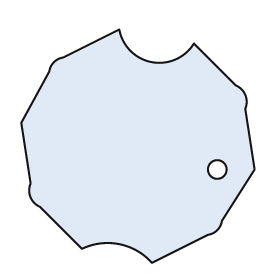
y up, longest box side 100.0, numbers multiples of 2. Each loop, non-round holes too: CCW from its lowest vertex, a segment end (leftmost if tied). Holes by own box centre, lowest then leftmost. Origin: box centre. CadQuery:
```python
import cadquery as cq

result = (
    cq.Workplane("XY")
    .moveTo(6.0, -50.0)
    .lineTo(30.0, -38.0)
    .threePointArc((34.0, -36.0), (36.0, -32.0))
    .lineTo(50.0, -10.0)
    .lineTo(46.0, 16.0)
    .threePointArc((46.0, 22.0), (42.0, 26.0))
    .lineTo(24.0, 44.0)
    .threePointArc((6.0, 36.0), (-8.0, 50.0))
    .lineTo(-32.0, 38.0)
    .threePointArc((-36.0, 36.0), (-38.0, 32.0))
    .lineTo(-50.0, 10.0)
    .lineTo(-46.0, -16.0)
    .threePointArc((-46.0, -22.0), (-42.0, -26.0))
    .lineTo(-24.0, -44.0)
    .threePointArc((-8.0, -42.0), (6.0, -50.0))
    .close()
    .moveTo(34.0, -10.0)
    .circle(4.0)
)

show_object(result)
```